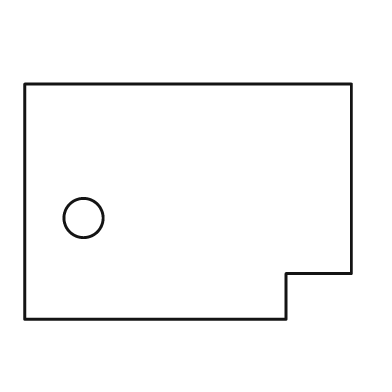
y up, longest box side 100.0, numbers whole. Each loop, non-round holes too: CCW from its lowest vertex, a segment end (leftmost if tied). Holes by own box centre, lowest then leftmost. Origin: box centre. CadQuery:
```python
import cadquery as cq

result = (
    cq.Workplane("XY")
    .moveTo(-50.0, -36.0)
    .lineTo(30.0, -36.0)
    .lineTo(30.0, -22.0)
    .lineTo(50.0, -22.0)
    .lineTo(50.0, 36.0)
    .lineTo(-50.0, 36.0)
    .close()
    .moveTo(-32.0, -5.0)
    .circle(6.0)
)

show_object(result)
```